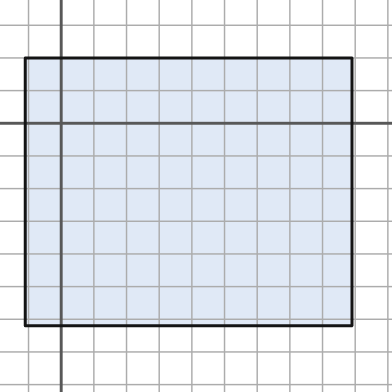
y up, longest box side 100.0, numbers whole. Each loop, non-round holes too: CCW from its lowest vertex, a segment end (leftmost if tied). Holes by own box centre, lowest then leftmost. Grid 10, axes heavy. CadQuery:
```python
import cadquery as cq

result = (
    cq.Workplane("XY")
    .moveTo(-11.0, -62.0)
    .lineTo(89.0, -62.0)
    .lineTo(89.0, 20.0)
    .lineTo(-11.0, 20.0)
    .close()
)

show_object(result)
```